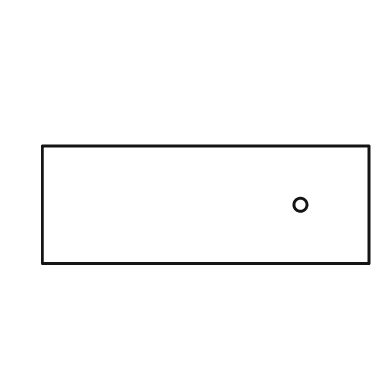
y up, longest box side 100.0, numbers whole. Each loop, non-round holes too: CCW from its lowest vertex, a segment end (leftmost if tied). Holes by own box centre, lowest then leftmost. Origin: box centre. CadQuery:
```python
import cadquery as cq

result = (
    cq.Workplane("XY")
    .moveTo(-50.0, -18.0)
    .lineTo(50.0, -18.0)
    .lineTo(50.0, 18.0)
    .lineTo(-50.0, 18.0)
    .close()
    .moveTo(29.0, 0.0)
    .circle(2.0)
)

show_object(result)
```